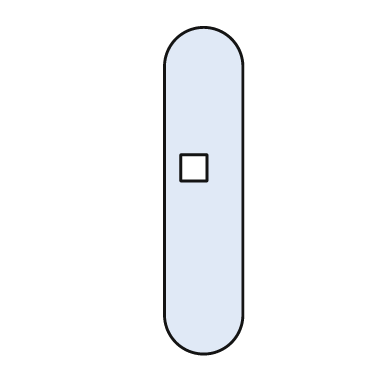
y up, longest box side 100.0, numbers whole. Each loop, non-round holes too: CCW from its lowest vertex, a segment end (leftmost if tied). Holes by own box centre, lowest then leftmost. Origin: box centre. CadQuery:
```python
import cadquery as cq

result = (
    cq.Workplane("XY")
    .moveTo(-12.0, -38.0)
    .threePointArc((0.0, -50.0), (12.0, -38.0))
    .lineTo(12.0, 38.0)
    .threePointArc((0.0, 50.0), (-12.0, 38.0))
    .close()
    .moveTo(-7.0, 3.0)
    .lineTo(1.0, 3.0)
    .lineTo(1.0, 11.0)
    .lineTo(-7.0, 11.0)
    .close()
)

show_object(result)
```